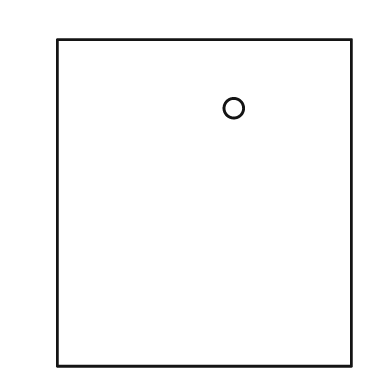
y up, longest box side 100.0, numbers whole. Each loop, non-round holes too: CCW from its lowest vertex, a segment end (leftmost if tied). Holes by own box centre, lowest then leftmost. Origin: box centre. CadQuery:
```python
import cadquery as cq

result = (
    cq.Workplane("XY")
    .moveTo(-45.0, -50.0)
    .lineTo(45.0, -50.0)
    .lineTo(45.0, 50.0)
    .lineTo(-45.0, 50.0)
    .close()
    .moveTo(9.0, 29.0)
    .circle(3.0)
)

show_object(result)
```